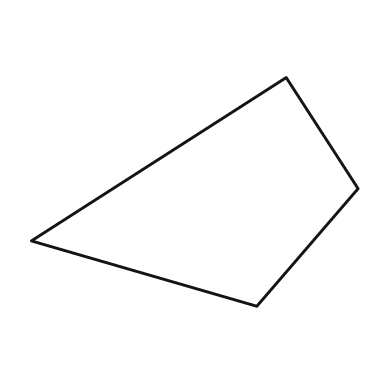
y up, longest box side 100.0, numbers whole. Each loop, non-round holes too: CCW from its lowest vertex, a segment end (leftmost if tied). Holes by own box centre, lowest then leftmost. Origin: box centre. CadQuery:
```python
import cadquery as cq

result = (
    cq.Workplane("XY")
    .moveTo(19.0, -35.0)
    .lineTo(50.0, 1.0)
    .lineTo(28.0, 35.0)
    .lineTo(-50.0, -15.0)
    .close()
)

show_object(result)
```